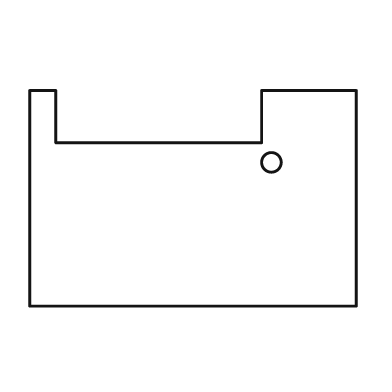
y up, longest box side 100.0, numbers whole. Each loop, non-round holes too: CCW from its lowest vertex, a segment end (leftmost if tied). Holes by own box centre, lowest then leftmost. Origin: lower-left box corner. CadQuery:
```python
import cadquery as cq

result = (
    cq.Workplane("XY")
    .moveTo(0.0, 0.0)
    .lineTo(100.0, 0.0)
    .lineTo(100.0, 66.0)
    .lineTo(71.0, 66.0)
    .lineTo(71.0, 50.0)
    .lineTo(8.0, 50.0)
    .lineTo(8.0, 66.0)
    .lineTo(0.0, 66.0)
    .close()
    .moveTo(74.0, 44.0)
    .circle(3.0)
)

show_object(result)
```